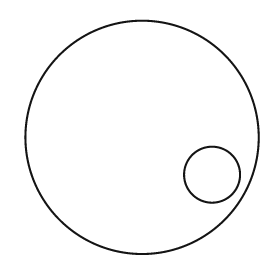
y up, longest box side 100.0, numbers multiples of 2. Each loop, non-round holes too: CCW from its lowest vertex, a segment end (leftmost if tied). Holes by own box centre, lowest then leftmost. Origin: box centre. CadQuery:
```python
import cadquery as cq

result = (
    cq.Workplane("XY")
    .moveTo(0.0, 0.0)
    .circle(50.0)
    .moveTo(30.0, -16.0)
    .circle(12.0)
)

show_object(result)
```